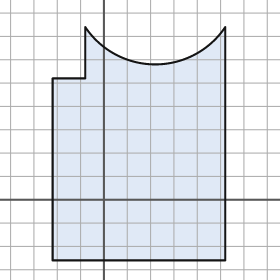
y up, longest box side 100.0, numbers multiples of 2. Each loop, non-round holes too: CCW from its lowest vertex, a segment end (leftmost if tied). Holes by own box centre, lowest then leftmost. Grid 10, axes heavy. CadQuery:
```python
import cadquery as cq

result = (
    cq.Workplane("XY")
    .moveTo(-22.0, -26.0)
    .lineTo(52.0, -26.0)
    .lineTo(52.0, 74.0)
    .threePointArc((22.0, 58.0), (-8.0, 74.0))
    .lineTo(-8.0, 52.0)
    .lineTo(-22.0, 52.0)
    .close()
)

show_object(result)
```